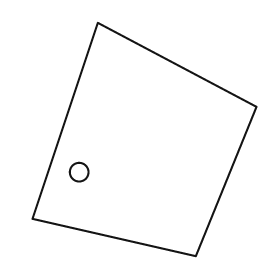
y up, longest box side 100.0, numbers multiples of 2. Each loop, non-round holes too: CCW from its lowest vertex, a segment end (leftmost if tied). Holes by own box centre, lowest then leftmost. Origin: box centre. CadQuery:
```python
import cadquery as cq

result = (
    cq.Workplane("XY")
    .moveTo(22.0, -50.0)
    .lineTo(48.0, 14.0)
    .lineTo(-20.0, 50.0)
    .lineTo(-48.0, -34.0)
    .close()
    .moveTo(-28.0, -14.0)
    .circle(4.0)
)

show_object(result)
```